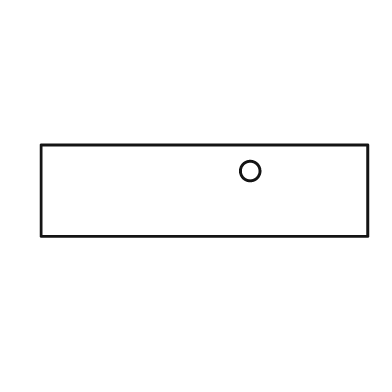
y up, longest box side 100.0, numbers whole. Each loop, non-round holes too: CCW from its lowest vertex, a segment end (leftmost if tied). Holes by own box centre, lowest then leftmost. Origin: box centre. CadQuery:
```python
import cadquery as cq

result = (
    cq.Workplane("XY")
    .moveTo(-50.0, -14.0)
    .lineTo(50.0, -14.0)
    .lineTo(50.0, 14.0)
    .lineTo(-50.0, 14.0)
    .close()
    .moveTo(14.0, 6.0)
    .circle(3.0)
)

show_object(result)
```